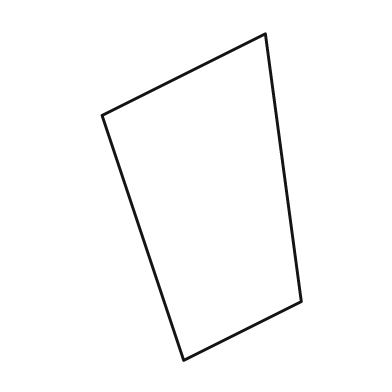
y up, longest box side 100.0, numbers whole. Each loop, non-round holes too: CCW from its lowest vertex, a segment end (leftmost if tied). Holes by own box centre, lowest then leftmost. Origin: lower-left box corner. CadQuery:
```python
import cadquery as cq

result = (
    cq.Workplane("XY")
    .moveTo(25.0, 0.0)
    .lineTo(61.0, 18.0)
    .lineTo(50.0, 100.0)
    .lineTo(0.0, 75.0)
    .close()
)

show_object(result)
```